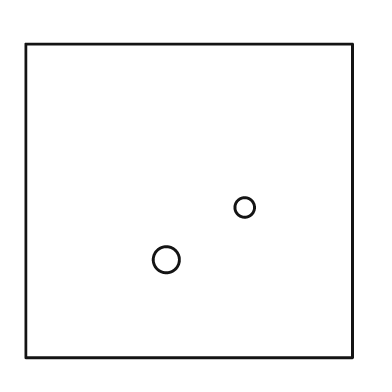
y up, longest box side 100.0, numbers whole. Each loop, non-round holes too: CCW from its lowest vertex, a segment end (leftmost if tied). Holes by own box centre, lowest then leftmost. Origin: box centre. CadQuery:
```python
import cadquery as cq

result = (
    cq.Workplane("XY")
    .moveTo(-50.0, -48.0)
    .lineTo(50.0, -48.0)
    .lineTo(50.0, 48.0)
    .lineTo(-50.0, 48.0)
    .close()
    .moveTo(-7.0, -18.0)
    .circle(4.0)
    .moveTo(17.0, -2.0)
    .circle(3.0)
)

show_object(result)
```